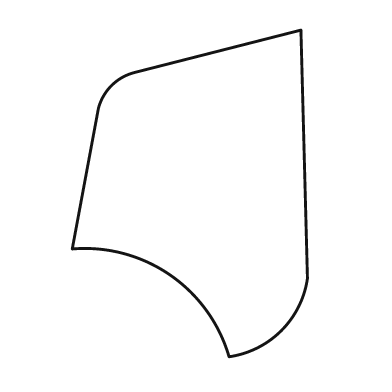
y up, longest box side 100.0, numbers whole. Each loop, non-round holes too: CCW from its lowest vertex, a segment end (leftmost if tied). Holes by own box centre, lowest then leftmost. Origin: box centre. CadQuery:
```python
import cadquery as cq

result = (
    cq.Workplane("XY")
    .moveTo(12.0, -50.0)
    .threePointArc((28.0, -42.0), (36.0, -26.0))
    .lineTo(34.0, 50.0)
    .lineTo(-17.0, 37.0)
    .threePointArc((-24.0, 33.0), (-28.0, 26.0))
    .lineTo(-36.0, -17.0)
    .threePointArc((-6.0, -25.0), (12.0, -50.0))
    .close()
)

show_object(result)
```